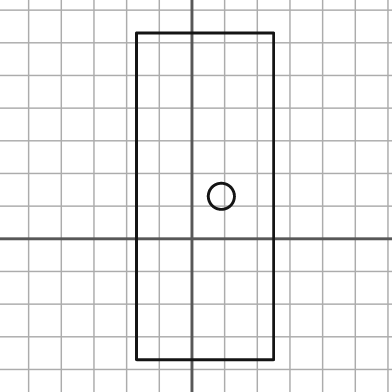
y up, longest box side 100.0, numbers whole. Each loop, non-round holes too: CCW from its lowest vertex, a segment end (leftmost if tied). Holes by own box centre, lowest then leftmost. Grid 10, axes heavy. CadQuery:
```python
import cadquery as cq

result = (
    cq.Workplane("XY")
    .moveTo(-17.0, -37.0)
    .lineTo(25.0, -37.0)
    .lineTo(25.0, 63.0)
    .lineTo(-17.0, 63.0)
    .close()
    .moveTo(9.0, 13.0)
    .circle(4.0)
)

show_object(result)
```